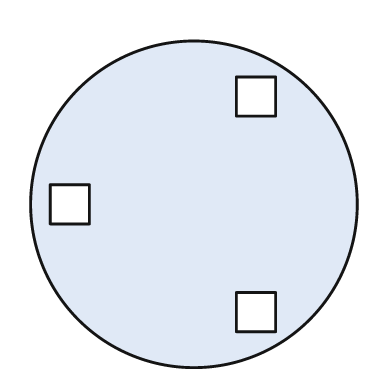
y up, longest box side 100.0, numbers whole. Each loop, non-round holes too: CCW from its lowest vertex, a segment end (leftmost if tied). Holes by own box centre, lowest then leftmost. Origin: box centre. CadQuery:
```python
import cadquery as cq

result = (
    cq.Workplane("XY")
    .moveTo(0.0, 0.0)
    .circle(50.0)
    .moveTo(13.0, -39.0)
    .lineTo(25.0, -39.0)
    .lineTo(25.0, -27.0)
    .lineTo(13.0, -27.0)
    .close()
    .moveTo(-44.0, -6.0)
    .lineTo(-32.0, -6.0)
    .lineTo(-32.0, 6.0)
    .lineTo(-44.0, 6.0)
    .close()
    .moveTo(13.0, 27.0)
    .lineTo(25.0, 27.0)
    .lineTo(25.0, 39.0)
    .lineTo(13.0, 39.0)
    .close()
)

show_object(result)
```